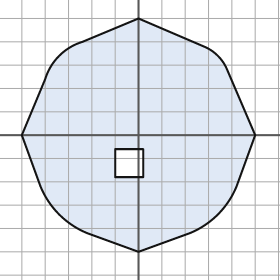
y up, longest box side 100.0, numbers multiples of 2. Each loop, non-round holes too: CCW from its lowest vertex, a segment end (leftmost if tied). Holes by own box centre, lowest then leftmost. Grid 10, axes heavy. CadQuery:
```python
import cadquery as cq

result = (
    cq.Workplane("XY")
    .moveTo(0.0, -50.0)
    .lineTo(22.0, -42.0)
    .threePointArc((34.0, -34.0), (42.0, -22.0))
    .lineTo(50.0, 0.0)
    .lineTo(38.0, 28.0)
    .threePointArc((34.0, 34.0), (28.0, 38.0))
    .lineTo(0.0, 50.0)
    .lineTo(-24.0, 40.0)
    .threePointArc((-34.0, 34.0), (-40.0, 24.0))
    .lineTo(-50.0, 0.0)
    .lineTo(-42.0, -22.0)
    .threePointArc((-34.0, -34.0), (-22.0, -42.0))
    .close()
    .moveTo(-10.0, -18.0)
    .lineTo(2.0, -18.0)
    .lineTo(2.0, -6.0)
    .lineTo(-10.0, -6.0)
    .close()
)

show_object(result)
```